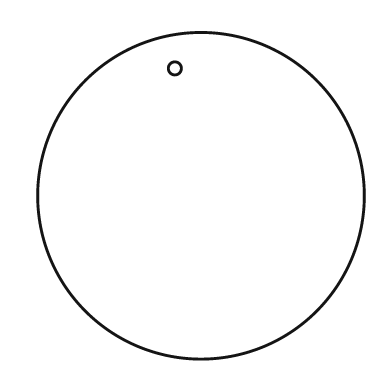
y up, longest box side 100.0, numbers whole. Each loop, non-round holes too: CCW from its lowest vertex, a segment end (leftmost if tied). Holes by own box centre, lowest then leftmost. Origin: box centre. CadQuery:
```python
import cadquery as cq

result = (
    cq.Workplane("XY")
    .moveTo(0.0, 0.0)
    .circle(50.0)
    .moveTo(-8.0, 39.0)
    .circle(2.0)
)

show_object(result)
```